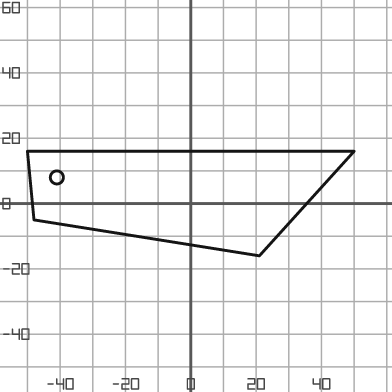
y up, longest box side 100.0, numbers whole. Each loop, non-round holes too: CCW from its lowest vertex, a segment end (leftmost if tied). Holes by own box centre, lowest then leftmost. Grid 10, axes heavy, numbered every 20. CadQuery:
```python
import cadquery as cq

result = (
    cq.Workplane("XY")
    .moveTo(21.0, -16.0)
    .lineTo(50.0, 16.0)
    .lineTo(-50.0, 16.0)
    .lineTo(-48.0, -5.0)
    .close()
    .moveTo(-41.0, 8.0)
    .circle(2.0)
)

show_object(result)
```